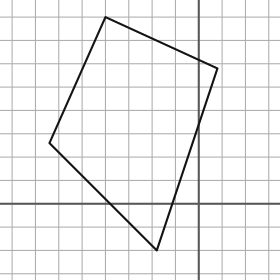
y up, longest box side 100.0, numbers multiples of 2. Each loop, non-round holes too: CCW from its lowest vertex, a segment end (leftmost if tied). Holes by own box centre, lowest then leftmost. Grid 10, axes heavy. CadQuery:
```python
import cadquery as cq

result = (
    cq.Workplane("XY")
    .moveTo(-18.0, -20.0)
    .lineTo(8.0, 58.0)
    .lineTo(-40.0, 80.0)
    .lineTo(-64.0, 26.0)
    .close()
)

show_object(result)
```